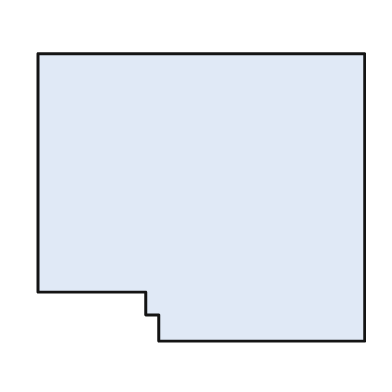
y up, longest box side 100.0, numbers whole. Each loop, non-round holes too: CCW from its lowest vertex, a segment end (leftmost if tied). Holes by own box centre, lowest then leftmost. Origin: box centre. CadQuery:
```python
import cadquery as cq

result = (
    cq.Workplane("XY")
    .moveTo(-13.0, -44.0)
    .lineTo(50.0, -44.0)
    .lineTo(50.0, 44.0)
    .lineTo(-50.0, 44.0)
    .lineTo(-50.0, -29.0)
    .lineTo(-17.0, -29.0)
    .lineTo(-17.0, -36.0)
    .lineTo(-13.0, -36.0)
    .close()
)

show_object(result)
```